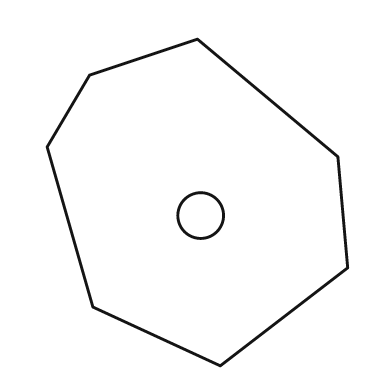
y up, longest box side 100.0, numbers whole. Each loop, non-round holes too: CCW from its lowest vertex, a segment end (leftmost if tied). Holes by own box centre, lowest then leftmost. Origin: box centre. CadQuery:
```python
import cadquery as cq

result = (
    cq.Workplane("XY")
    .moveTo(7.0, -50.0)
    .lineTo(46.0, -20.0)
    .lineTo(43.0, 14.0)
    .lineTo(0.0, 50.0)
    .lineTo(-33.0, 39.0)
    .lineTo(-46.0, 17.0)
    .lineTo(-32.0, -32.0)
    .close()
    .moveTo(1.0, -4.0)
    .circle(7.0)
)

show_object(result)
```